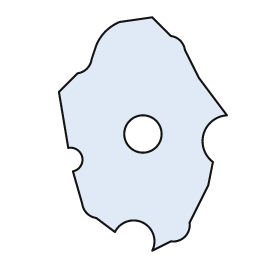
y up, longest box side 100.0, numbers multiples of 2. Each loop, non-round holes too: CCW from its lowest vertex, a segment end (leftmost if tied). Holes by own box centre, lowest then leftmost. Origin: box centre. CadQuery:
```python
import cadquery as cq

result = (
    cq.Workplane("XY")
    .moveTo(4.0, -50.0)
    .lineTo(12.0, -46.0)
    .threePointArc((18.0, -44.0), (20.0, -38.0))
    .lineTo(28.0, -22.0)
    .lineTo(30.0, -12.0)
    .threePointArc((26.0, 0.0), (36.0, 8.0))
    .lineTo(24.0, 24.0)
    .lineTo(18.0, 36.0)
    .threePointArc((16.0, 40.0), (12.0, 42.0))
    .lineTo(4.0, 50.0)
    .lineTo(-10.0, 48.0)
    .threePointArc((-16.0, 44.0), (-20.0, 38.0))
    .lineTo(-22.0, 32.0)
    .threePointArc((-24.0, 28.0), (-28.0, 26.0))
    .lineTo(-36.0, 18.0)
    .lineTo(-32.0, -6.0)
    .threePointArc((-26.0, -10.0), (-30.0, -16.0))
    .lineTo(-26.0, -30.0)
    .threePointArc((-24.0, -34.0), (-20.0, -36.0))
    .lineTo(-12.0, -42.0)
    .threePointArc((0.0, -38.0), (4.0, -50.0))
    .close()
    .moveTo(0.0, 0.0)
    .circle(8.0)
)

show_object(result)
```